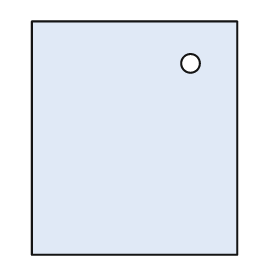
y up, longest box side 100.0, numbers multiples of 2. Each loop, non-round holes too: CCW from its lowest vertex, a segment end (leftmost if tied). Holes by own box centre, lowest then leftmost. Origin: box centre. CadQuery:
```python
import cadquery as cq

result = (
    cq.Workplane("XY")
    .moveTo(-44.0, -50.0)
    .lineTo(44.0, -50.0)
    .lineTo(44.0, 50.0)
    .lineTo(-44.0, 50.0)
    .close()
    .moveTo(24.0, 32.0)
    .circle(4.0)
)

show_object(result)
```